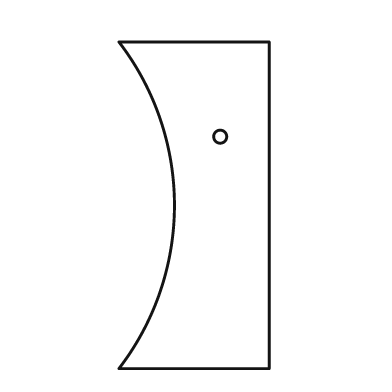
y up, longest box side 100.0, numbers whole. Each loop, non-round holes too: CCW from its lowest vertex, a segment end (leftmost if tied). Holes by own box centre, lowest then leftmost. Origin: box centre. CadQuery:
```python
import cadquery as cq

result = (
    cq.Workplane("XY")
    .moveTo(-23.0, -50.0)
    .lineTo(23.0, -50.0)
    .lineTo(23.0, 50.0)
    .lineTo(-23.0, 50.0)
    .threePointArc((-6.0, 0.0), (-23.0, -50.0))
    .close()
    .moveTo(8.0, 21.0)
    .circle(2.0)
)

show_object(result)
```